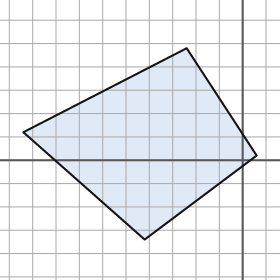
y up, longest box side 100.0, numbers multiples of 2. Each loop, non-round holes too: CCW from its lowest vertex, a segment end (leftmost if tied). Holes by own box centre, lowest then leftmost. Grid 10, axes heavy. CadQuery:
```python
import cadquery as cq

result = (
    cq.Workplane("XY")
    .moveTo(-42.0, -34.0)
    .lineTo(6.0, 2.0)
    .lineTo(-24.0, 48.0)
    .lineTo(-94.0, 12.0)
    .close()
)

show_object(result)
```